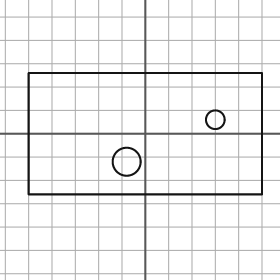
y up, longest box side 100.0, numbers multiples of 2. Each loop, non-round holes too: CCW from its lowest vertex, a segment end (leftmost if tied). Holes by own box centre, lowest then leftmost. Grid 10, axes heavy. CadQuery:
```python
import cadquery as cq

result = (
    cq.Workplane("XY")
    .moveTo(-50.0, -26.0)
    .lineTo(50.0, -26.0)
    .lineTo(50.0, 26.0)
    .lineTo(-50.0, 26.0)
    .close()
    .moveTo(-8.0, -12.0)
    .circle(6.0)
    .moveTo(30.0, 6.0)
    .circle(4.0)
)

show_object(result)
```